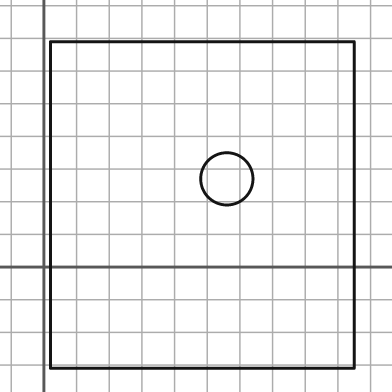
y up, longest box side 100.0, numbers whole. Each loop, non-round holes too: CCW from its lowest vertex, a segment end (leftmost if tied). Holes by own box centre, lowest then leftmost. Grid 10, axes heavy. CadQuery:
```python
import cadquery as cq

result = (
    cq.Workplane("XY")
    .moveTo(2.0, -31.0)
    .lineTo(95.0, -31.0)
    .lineTo(95.0, 69.0)
    .lineTo(2.0, 69.0)
    .close()
    .moveTo(56.0, 27.0)
    .circle(8.0)
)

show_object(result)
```